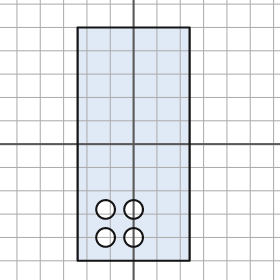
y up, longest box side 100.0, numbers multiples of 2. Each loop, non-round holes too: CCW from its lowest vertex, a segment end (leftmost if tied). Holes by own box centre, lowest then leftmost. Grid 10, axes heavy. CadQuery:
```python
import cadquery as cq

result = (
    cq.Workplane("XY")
    .moveTo(-24.0, -50.0)
    .lineTo(24.0, -50.0)
    .lineTo(24.0, 50.0)
    .lineTo(-24.0, 50.0)
    .close()
    .moveTo(-12.0, -40.0)
    .circle(4.0)
    .moveTo(0.0, -40.0)
    .circle(4.0)
    .moveTo(-12.0, -28.0)
    .circle(4.0)
    .moveTo(0.0, -28.0)
    .circle(4.0)
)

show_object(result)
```